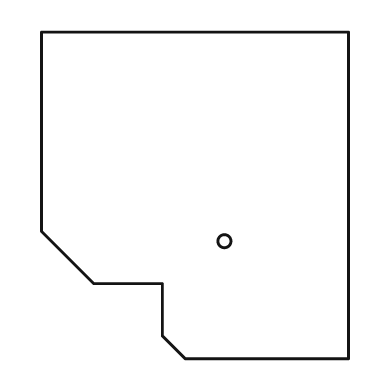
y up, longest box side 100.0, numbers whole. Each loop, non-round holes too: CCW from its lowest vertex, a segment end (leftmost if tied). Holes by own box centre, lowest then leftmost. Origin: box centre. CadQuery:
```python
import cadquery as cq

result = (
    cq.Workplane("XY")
    .moveTo(-3.0, -50.0)
    .lineTo(47.0, -50.0)
    .lineTo(47.0, 50.0)
    .lineTo(-47.0, 50.0)
    .lineTo(-47.0, -11.0)
    .lineTo(-31.0, -27.0)
    .lineTo(-10.0, -27.0)
    .lineTo(-10.0, -43.0)
    .close()
    .moveTo(9.0, -14.0)
    .circle(2.0)
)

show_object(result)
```